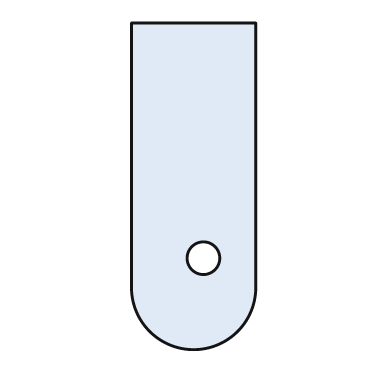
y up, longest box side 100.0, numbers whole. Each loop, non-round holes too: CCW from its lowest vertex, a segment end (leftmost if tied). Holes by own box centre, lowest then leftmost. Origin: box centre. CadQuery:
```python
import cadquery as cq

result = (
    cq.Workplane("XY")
    .moveTo(-19.0, -32.0)
    .threePointArc((0.0, -50.0), (19.0, -32.0))
    .lineTo(19.0, 50.0)
    .lineTo(-19.0, 50.0)
    .close()
    .moveTo(3.0, -22.0)
    .circle(5.0)
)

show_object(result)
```